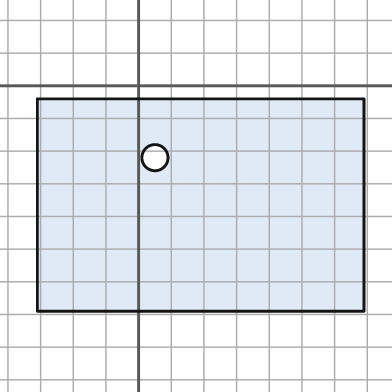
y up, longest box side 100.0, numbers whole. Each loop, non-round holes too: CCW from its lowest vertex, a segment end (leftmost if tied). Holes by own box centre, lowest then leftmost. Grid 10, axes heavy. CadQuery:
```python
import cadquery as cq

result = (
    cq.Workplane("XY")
    .moveTo(-31.0, -69.0)
    .lineTo(69.0, -69.0)
    .lineTo(69.0, -4.0)
    .lineTo(-31.0, -4.0)
    .close()
    .moveTo(5.0, -22.0)
    .circle(4.0)
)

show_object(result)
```